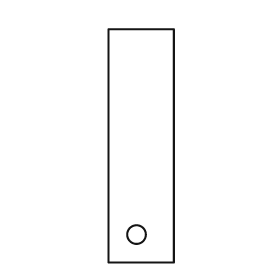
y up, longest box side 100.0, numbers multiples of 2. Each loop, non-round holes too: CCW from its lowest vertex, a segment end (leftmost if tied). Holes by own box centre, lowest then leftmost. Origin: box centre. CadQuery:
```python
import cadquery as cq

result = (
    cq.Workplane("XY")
    .moveTo(-14.0, -50.0)
    .lineTo(14.0, -50.0)
    .lineTo(14.0, 50.0)
    .lineTo(-14.0, 50.0)
    .close()
    .moveTo(-2.0, -38.0)
    .circle(4.0)
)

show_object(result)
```